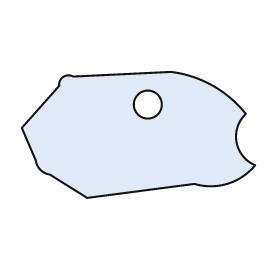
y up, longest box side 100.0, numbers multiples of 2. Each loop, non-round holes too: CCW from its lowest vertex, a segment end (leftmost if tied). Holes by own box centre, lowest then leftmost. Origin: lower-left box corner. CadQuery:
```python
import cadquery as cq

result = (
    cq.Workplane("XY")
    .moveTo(28.0, 0.0)
    .lineTo(74.0, 6.0)
    .threePointArc((88.0, 6.0), (100.0, 14.0))
    .threePointArc((92.0, 24.0), (96.0, 36.0))
    .threePointArc((82.0, 48.0), (64.0, 54.0))
    .lineTo(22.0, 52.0)
    .threePointArc((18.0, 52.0), (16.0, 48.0))
    .lineTo(0.0, 30.0)
    .lineTo(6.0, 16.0)
    .threePointArc((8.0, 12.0), (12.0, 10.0))
    .close()
    .moveTo(54.0, 40.0)
    .circle(6.0)
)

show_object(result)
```